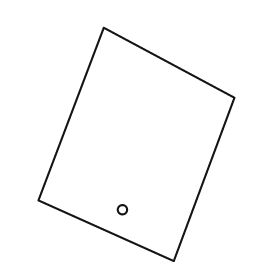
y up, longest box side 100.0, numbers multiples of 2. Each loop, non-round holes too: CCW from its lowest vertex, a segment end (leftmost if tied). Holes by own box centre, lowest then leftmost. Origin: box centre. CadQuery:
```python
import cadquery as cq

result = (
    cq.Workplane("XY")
    .moveTo(16.0, -50.0)
    .lineTo(42.0, 20.0)
    .lineTo(-14.0, 50.0)
    .lineTo(-42.0, -24.0)
    .close()
    .moveTo(-6.0, -28.0)
    .circle(2.0)
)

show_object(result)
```